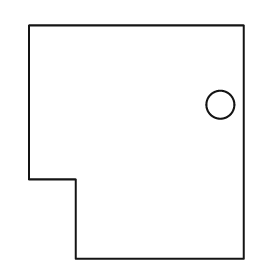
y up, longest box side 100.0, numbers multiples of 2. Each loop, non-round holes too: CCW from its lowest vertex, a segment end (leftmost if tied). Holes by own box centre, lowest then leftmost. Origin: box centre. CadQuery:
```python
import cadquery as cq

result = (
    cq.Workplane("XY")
    .moveTo(-26.0, -50.0)
    .lineTo(46.0, -50.0)
    .lineTo(46.0, 50.0)
    .lineTo(-46.0, 50.0)
    .lineTo(-46.0, -16.0)
    .lineTo(-26.0, -16.0)
    .close()
    .moveTo(36.0, 16.0)
    .circle(6.0)
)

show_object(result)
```